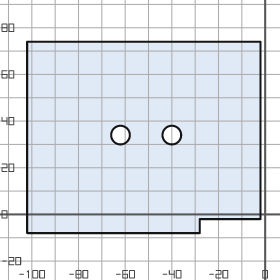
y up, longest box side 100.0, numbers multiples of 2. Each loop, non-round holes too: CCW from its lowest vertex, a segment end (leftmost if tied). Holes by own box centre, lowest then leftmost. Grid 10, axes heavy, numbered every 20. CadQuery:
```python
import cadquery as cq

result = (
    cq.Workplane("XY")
    .moveTo(-102.0, -8.0)
    .lineTo(-28.0, -8.0)
    .lineTo(-28.0, -2.0)
    .lineTo(-2.0, -2.0)
    .lineTo(-2.0, 74.0)
    .lineTo(-102.0, 74.0)
    .close()
    .moveTo(-62.0, 34.0)
    .circle(4.0)
    .moveTo(-40.0, 34.0)
    .circle(4.0)
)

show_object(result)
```